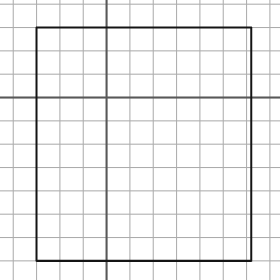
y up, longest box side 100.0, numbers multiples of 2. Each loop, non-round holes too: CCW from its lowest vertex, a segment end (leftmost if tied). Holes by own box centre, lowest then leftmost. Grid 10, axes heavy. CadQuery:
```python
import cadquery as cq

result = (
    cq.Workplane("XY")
    .moveTo(-30.0, -70.0)
    .lineTo(62.0, -70.0)
    .lineTo(62.0, 30.0)
    .lineTo(-30.0, 30.0)
    .close()
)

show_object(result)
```